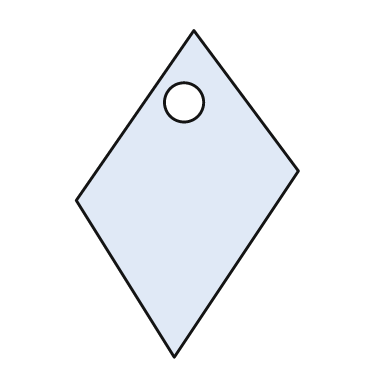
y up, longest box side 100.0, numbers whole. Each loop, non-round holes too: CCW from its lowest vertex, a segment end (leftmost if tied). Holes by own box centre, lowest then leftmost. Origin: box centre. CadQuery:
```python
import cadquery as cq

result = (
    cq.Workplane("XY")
    .moveTo(-4.0, -50.0)
    .lineTo(34.0, 7.0)
    .lineTo(2.0, 50.0)
    .lineTo(-34.0, -2.0)
    .close()
    .moveTo(-1.0, 28.0)
    .circle(6.0)
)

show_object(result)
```